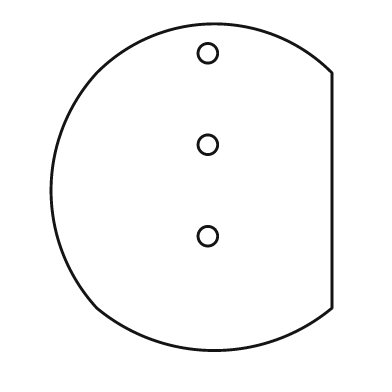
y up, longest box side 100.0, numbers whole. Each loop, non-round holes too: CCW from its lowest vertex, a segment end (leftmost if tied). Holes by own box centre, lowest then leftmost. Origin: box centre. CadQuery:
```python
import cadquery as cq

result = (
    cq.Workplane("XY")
    .moveTo(-29.0, -37.0)
    .threePointArc((7.0, -50.0), (43.0, -37.0))
    .lineTo(43.0, 35.0)
    .threePointArc((7.0, 50.0), (-29.0, 35.0))
    .threePointArc((-43.0, -1.0), (-29.0, -37.0))
    .close()
    .moveTo(5.0, -15.0)
    .circle(3.0)
    .moveTo(5.0, 13.0)
    .circle(3.0)
    .moveTo(5.0, 41.0)
    .circle(3.0)
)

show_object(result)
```